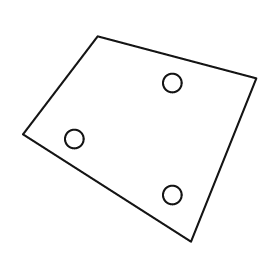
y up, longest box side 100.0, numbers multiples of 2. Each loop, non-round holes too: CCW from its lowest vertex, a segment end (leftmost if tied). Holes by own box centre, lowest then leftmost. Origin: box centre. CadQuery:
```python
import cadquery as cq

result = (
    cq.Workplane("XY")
    .moveTo(22.0, -44.0)
    .lineTo(50.0, 26.0)
    .lineTo(-18.0, 44.0)
    .lineTo(-50.0, 2.0)
    .close()
    .moveTo(14.0, -24.0)
    .circle(4.0)
    .moveTo(-28.0, 0.0)
    .circle(4.0)
    .moveTo(14.0, 24.0)
    .circle(4.0)
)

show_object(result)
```